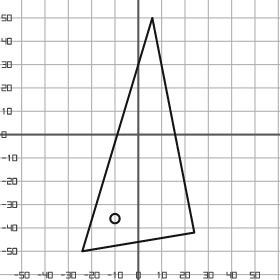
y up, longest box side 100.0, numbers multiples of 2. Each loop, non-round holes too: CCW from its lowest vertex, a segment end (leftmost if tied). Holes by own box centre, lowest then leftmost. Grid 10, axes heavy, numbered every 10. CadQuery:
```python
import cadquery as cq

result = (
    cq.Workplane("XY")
    .moveTo(-24.0, -50.0)
    .lineTo(24.0, -42.0)
    .lineTo(6.0, 50.0)
    .close()
    .moveTo(-10.0, -36.0)
    .circle(2.0)
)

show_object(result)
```